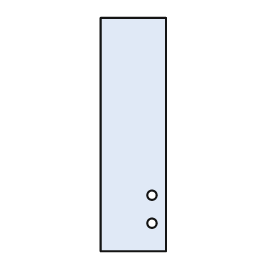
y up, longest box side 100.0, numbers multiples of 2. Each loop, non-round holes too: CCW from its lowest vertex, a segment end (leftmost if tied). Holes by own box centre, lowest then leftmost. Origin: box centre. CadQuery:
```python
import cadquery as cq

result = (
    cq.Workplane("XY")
    .moveTo(-14.0, -50.0)
    .lineTo(14.0, -50.0)
    .lineTo(14.0, 50.0)
    .lineTo(-14.0, 50.0)
    .close()
    .moveTo(8.0, -38.0)
    .circle(2.0)
    .moveTo(8.0, -26.0)
    .circle(2.0)
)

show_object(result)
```